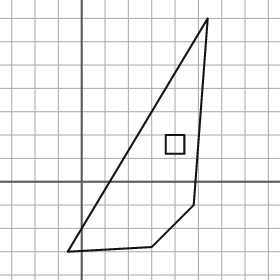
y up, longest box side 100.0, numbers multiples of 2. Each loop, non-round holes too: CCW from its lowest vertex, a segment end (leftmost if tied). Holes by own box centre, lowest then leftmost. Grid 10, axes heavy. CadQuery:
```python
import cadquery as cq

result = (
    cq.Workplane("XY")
    .moveTo(-6.0, -30.0)
    .lineTo(30.0, -28.0)
    .lineTo(48.0, -10.0)
    .lineTo(54.0, 70.0)
    .close()
    .moveTo(36.0, 12.0)
    .lineTo(44.0, 12.0)
    .lineTo(44.0, 20.0)
    .lineTo(36.0, 20.0)
    .close()
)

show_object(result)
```